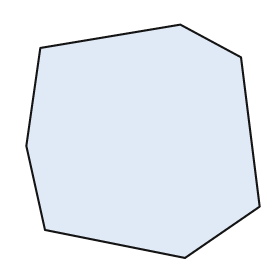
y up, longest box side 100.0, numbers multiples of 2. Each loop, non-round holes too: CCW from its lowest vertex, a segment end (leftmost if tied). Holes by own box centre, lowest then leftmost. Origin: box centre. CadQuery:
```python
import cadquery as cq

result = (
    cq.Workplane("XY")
    .moveTo(18.0, -50.0)
    .lineTo(50.0, -28.0)
    .lineTo(42.0, 36.0)
    .lineTo(16.0, 50.0)
    .lineTo(-44.0, 40.0)
    .lineTo(-50.0, -2.0)
    .lineTo(-42.0, -38.0)
    .close()
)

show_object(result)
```